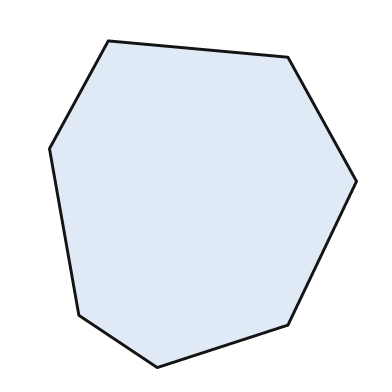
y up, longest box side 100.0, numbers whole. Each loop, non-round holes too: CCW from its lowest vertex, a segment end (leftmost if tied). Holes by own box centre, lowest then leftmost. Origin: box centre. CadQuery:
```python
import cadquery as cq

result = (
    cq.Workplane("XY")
    .moveTo(-14.0, -50.0)
    .lineTo(26.0, -37.0)
    .lineTo(47.0, 7.0)
    .lineTo(26.0, 45.0)
    .lineTo(-29.0, 50.0)
    .lineTo(-47.0, 17.0)
    .lineTo(-38.0, -34.0)
    .close()
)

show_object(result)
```